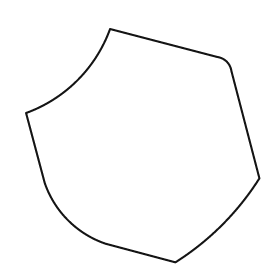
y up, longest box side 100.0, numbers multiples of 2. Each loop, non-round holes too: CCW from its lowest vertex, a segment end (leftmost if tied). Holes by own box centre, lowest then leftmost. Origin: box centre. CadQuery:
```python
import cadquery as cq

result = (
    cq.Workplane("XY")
    .moveTo(14.0, -50.0)
    .threePointArc((34.0, -34.0), (50.0, -14.0))
    .lineTo(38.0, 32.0)
    .threePointArc((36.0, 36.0), (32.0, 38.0))
    .lineTo(-14.0, 50.0)
    .threePointArc((-28.0, 28.0), (-50.0, 14.0))
    .lineTo(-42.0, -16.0)
    .threePointArc((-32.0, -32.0), (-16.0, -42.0))
    .close()
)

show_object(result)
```